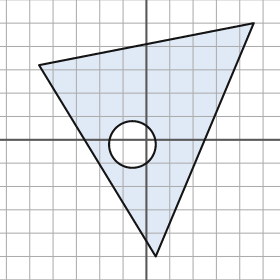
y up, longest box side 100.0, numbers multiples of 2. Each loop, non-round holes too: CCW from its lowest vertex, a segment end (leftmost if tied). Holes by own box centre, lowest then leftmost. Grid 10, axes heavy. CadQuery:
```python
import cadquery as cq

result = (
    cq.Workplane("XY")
    .moveTo(4.0, -50.0)
    .lineTo(46.0, 50.0)
    .lineTo(-46.0, 32.0)
    .close()
    .moveTo(-6.0, -2.0)
    .circle(10.0)
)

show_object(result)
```